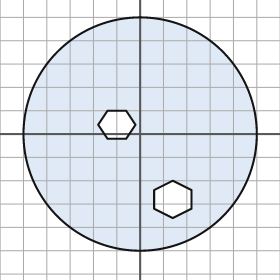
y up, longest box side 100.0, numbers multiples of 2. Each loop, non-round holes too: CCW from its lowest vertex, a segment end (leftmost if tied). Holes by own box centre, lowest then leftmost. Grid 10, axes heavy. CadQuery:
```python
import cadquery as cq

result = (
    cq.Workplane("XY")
    .moveTo(0.0, 0.0)
    .circle(50.0)
    .moveTo(14.0, -36.0)
    .lineTo(22.0, -32.0)
    .lineTo(22.0, -24.0)
    .lineTo(14.0, -20.0)
    .lineTo(6.0, -24.0)
    .lineTo(6.0, -32.0)
    .close()
    .moveTo(-14.0, -2.0)
    .lineTo(-6.0, -2.0)
    .lineTo(-2.0, 4.0)
    .lineTo(-6.0, 10.0)
    .lineTo(-14.0, 10.0)
    .lineTo(-18.0, 4.0)
    .close()
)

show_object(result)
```